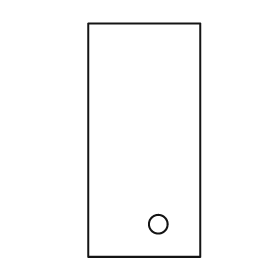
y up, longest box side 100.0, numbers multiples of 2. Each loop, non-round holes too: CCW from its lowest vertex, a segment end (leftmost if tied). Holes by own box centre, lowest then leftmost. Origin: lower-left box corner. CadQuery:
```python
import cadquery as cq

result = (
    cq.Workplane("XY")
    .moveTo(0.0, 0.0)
    .lineTo(48.0, 0.0)
    .lineTo(48.0, 100.0)
    .lineTo(0.0, 100.0)
    .close()
    .moveTo(30.0, 14.0)
    .circle(4.0)
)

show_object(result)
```